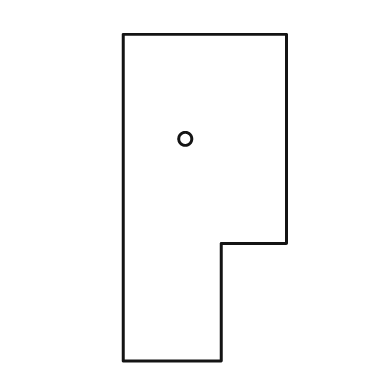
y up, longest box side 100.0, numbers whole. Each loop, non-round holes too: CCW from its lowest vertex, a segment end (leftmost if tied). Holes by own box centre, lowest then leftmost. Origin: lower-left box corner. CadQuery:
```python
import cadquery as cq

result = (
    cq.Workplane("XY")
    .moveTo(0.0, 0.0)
    .lineTo(30.0, 0.0)
    .lineTo(30.0, 36.0)
    .lineTo(50.0, 36.0)
    .lineTo(50.0, 100.0)
    .lineTo(0.0, 100.0)
    .close()
    .moveTo(19.0, 68.0)
    .circle(2.0)
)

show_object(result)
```